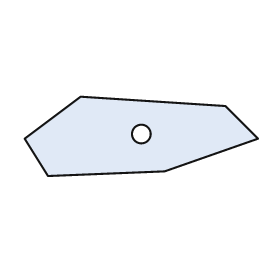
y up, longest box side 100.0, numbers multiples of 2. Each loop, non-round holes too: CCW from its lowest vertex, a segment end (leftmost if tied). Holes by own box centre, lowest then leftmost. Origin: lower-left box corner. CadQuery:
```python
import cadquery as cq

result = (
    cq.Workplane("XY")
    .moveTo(10.0, 0.0)
    .lineTo(60.0, 2.0)
    .lineTo(100.0, 16.0)
    .lineTo(86.0, 30.0)
    .lineTo(24.0, 34.0)
    .lineTo(0.0, 16.0)
    .close()
    .moveTo(50.0, 18.0)
    .circle(4.0)
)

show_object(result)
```